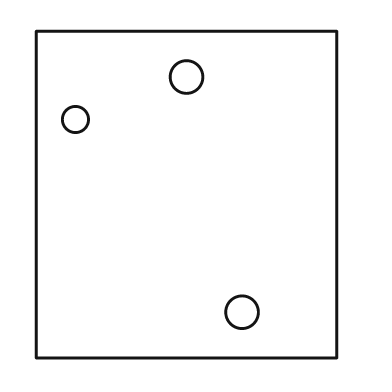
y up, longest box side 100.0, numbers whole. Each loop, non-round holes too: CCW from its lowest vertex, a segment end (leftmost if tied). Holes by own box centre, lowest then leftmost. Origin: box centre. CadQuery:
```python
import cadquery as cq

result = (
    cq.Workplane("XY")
    .moveTo(-46.0, -50.0)
    .lineTo(46.0, -50.0)
    .lineTo(46.0, 50.0)
    .lineTo(-46.0, 50.0)
    .close()
    .moveTo(17.0, -36.0)
    .circle(5.0)
    .moveTo(-34.0, 23.0)
    .circle(4.0)
    .moveTo(0.0, 36.0)
    .circle(5.0)
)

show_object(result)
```